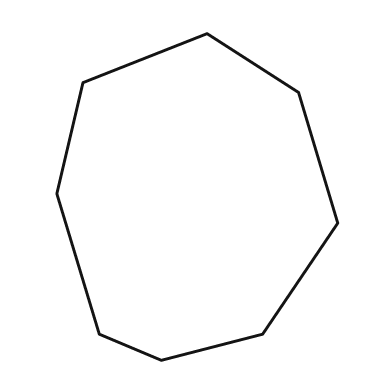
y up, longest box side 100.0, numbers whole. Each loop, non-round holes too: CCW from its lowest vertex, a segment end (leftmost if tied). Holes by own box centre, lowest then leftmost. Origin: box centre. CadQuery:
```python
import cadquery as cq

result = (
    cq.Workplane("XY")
    .moveTo(-11.0, -50.0)
    .lineTo(20.0, -42.0)
    .lineTo(43.0, -8.0)
    .lineTo(31.0, 32.0)
    .lineTo(3.0, 50.0)
    .lineTo(-35.0, 35.0)
    .lineTo(-43.0, 1.0)
    .lineTo(-30.0, -42.0)
    .close()
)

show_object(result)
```